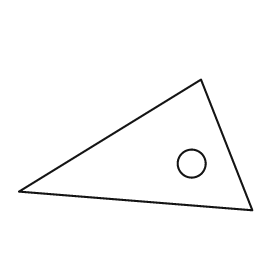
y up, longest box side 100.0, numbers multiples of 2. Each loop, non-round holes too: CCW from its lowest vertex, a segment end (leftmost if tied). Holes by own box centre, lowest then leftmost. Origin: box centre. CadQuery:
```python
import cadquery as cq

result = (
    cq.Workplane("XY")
    .moveTo(50.0, -28.0)
    .lineTo(28.0, 28.0)
    .lineTo(-50.0, -20.0)
    .close()
    .moveTo(24.0, -8.0)
    .circle(6.0)
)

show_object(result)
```